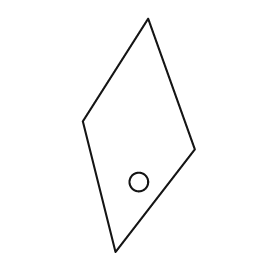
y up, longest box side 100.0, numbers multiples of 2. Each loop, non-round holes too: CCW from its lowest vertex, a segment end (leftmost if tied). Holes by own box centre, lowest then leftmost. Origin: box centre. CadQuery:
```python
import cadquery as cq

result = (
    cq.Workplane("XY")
    .moveTo(-10.0, -50.0)
    .lineTo(24.0, -6.0)
    .lineTo(4.0, 50.0)
    .lineTo(-24.0, 6.0)
    .close()
    .moveTo(0.0, -20.0)
    .circle(4.0)
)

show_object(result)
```